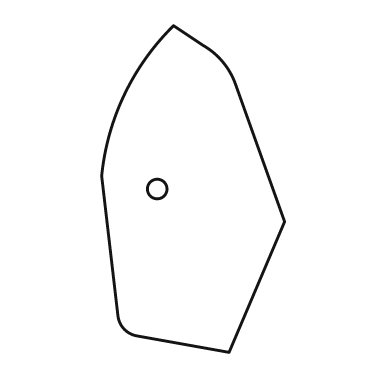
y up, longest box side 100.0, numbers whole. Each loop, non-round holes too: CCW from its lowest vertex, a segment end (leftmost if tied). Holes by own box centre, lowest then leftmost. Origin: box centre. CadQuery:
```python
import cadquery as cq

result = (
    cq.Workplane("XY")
    .moveTo(11.0, -50.0)
    .lineTo(28.0, -10.0)
    .lineTo(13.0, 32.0)
    .threePointArc((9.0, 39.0), (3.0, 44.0))
    .lineTo(-6.0, 50.0)
    .threePointArc((-21.0, 29.0), (-28.0, 4.0))
    .lineTo(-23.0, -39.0)
    .threePointArc((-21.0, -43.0), (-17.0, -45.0))
    .close()
    .moveTo(-11.0, 0.0)
    .circle(3.0)
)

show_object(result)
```